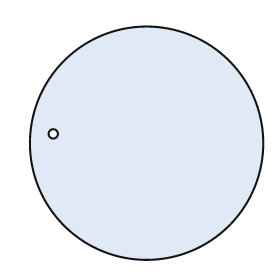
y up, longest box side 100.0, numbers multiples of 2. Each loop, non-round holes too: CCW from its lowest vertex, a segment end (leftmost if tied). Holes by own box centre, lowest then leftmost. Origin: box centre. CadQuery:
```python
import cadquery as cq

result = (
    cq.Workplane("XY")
    .moveTo(0.0, 0.0)
    .circle(50.0)
    .moveTo(-40.0, 4.0)
    .circle(2.0)
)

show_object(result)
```